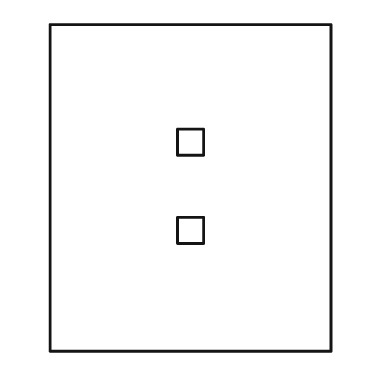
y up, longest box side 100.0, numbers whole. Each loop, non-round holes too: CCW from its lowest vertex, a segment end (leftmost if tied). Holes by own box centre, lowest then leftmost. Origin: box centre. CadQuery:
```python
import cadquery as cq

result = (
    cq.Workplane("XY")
    .moveTo(-43.0, -50.0)
    .lineTo(43.0, -50.0)
    .lineTo(43.0, 50.0)
    .lineTo(-43.0, 50.0)
    .close()
    .moveTo(-4.0, -17.0)
    .lineTo(4.0, -17.0)
    .lineTo(4.0, -9.0)
    .lineTo(-4.0, -9.0)
    .close()
    .moveTo(-4.0, 10.0)
    .lineTo(4.0, 10.0)
    .lineTo(4.0, 18.0)
    .lineTo(-4.0, 18.0)
    .close()
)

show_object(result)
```